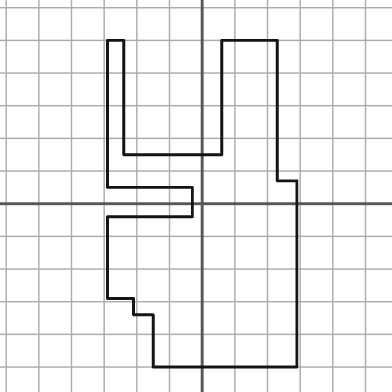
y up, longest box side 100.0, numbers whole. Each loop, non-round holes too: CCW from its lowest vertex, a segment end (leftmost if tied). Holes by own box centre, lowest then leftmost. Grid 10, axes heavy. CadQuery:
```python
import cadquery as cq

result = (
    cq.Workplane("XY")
    .moveTo(-15.0, -50.0)
    .lineTo(29.0, -50.0)
    .lineTo(29.0, 7.0)
    .lineTo(23.0, 7.0)
    .lineTo(23.0, 50.0)
    .lineTo(6.0, 50.0)
    .lineTo(6.0, 15.0)
    .lineTo(-24.0, 15.0)
    .lineTo(-24.0, 50.0)
    .lineTo(-29.0, 50.0)
    .lineTo(-29.0, 5.0)
    .lineTo(-3.0, 5.0)
    .lineTo(-3.0, -4.0)
    .lineTo(-29.0, -4.0)
    .lineTo(-29.0, -29.0)
    .lineTo(-21.0, -29.0)
    .lineTo(-21.0, -34.0)
    .lineTo(-15.0, -34.0)
    .close()
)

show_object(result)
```